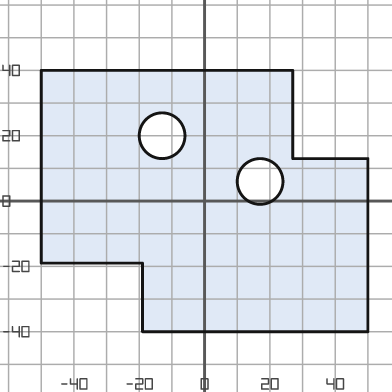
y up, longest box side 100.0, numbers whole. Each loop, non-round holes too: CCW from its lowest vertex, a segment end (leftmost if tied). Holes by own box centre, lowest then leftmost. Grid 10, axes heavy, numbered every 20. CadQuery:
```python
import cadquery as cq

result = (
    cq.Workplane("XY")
    .moveTo(-19.0, -40.0)
    .lineTo(50.0, -40.0)
    .lineTo(50.0, 13.0)
    .lineTo(27.0, 13.0)
    .lineTo(27.0, 40.0)
    .lineTo(-50.0, 40.0)
    .lineTo(-50.0, -19.0)
    .lineTo(-19.0, -19.0)
    .close()
    .moveTo(17.0, 6.0)
    .circle(7.0)
    .moveTo(-13.0, 20.0)
    .circle(7.0)
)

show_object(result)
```